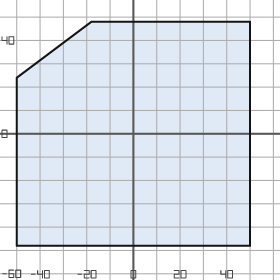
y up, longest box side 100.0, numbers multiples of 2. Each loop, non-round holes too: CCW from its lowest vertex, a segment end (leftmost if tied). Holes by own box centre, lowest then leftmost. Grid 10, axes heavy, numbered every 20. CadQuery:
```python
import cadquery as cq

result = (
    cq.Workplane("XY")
    .moveTo(-50.0, -48.0)
    .lineTo(50.0, -48.0)
    .lineTo(50.0, 48.0)
    .lineTo(-18.0, 48.0)
    .lineTo(-50.0, 24.0)
    .close()
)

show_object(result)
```